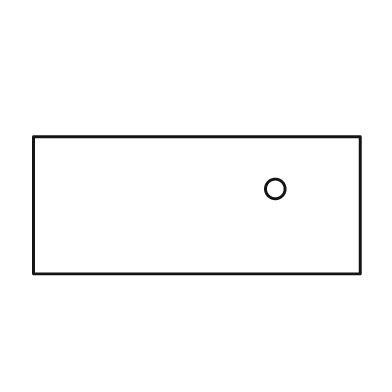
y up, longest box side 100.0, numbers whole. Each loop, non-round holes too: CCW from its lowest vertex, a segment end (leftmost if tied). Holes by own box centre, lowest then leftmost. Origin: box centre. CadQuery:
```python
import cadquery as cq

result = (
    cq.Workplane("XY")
    .moveTo(-50.0, -21.0)
    .lineTo(50.0, -21.0)
    .lineTo(50.0, 21.0)
    .lineTo(-50.0, 21.0)
    .close()
    .moveTo(24.0, 5.0)
    .circle(3.0)
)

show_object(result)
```